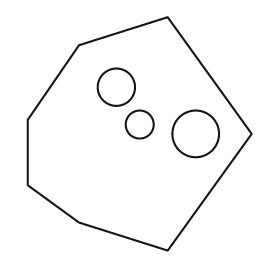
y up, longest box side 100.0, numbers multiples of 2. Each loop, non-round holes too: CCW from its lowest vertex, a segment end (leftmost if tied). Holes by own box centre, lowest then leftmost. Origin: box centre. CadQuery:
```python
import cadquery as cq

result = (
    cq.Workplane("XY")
    .moveTo(12.0, -50.0)
    .lineTo(48.0, 0.0)
    .lineTo(12.0, 50.0)
    .lineTo(-26.0, 38.0)
    .lineTo(-48.0, 6.0)
    .lineTo(-48.0, -22.0)
    .lineTo(-26.0, -38.0)
    .close()
    .moveTo(24.0, 0.0)
    .circle(10.0)
    .moveTo(0.0, 4.0)
    .circle(6.0)
    .moveTo(-10.0, 20.0)
    .circle(8.0)
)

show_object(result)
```